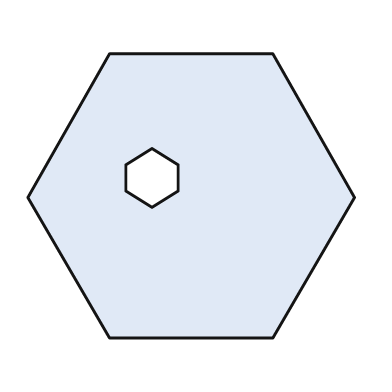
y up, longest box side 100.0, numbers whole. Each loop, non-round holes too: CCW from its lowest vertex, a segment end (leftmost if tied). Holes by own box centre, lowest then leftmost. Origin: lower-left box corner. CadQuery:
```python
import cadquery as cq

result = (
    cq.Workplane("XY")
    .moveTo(25.0, 0.0)
    .lineTo(75.0, 0.0)
    .lineTo(100.0, 43.0)
    .lineTo(75.0, 87.0)
    .lineTo(25.0, 87.0)
    .lineTo(0.0, 43.0)
    .close()
    .moveTo(38.0, 40.0)
    .lineTo(46.0, 45.0)
    .lineTo(46.0, 53.0)
    .lineTo(38.0, 58.0)
    .lineTo(30.0, 53.0)
    .lineTo(30.0, 45.0)
    .close()
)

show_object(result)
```